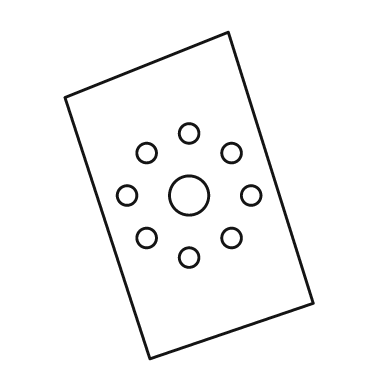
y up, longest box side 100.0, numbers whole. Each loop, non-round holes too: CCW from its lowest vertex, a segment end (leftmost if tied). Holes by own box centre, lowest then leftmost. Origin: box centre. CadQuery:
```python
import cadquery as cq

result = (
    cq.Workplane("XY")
    .moveTo(-12.0, -50.0)
    .lineTo(38.0, -33.0)
    .lineTo(12.0, 50.0)
    .lineTo(-38.0, 30.0)
    .close()
    .moveTo(0.0, -19.0)
    .circle(3.0)
    .moveTo(-13.0, -13.0)
    .circle(3.0)
    .moveTo(13.0, -13.0)
    .circle(3.0)
    .moveTo(-19.0, 0.0)
    .circle(3.0)
    .moveTo(0.0, 0.0)
    .circle(6.0)
    .moveTo(19.0, 0.0)
    .circle(3.0)
    .moveTo(-13.0, 13.0)
    .circle(3.0)
    .moveTo(13.0, 13.0)
    .circle(3.0)
    .moveTo(0.0, 19.0)
    .circle(3.0)
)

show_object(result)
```